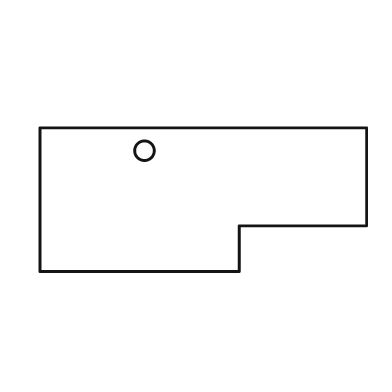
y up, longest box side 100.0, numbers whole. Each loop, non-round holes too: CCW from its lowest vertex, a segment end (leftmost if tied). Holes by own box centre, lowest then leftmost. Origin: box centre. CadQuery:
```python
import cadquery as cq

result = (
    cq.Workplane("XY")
    .moveTo(-50.0, -22.0)
    .lineTo(11.0, -22.0)
    .lineTo(11.0, -8.0)
    .lineTo(50.0, -8.0)
    .lineTo(50.0, 22.0)
    .lineTo(-50.0, 22.0)
    .close()
    .moveTo(-18.0, 15.0)
    .circle(3.0)
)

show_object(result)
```